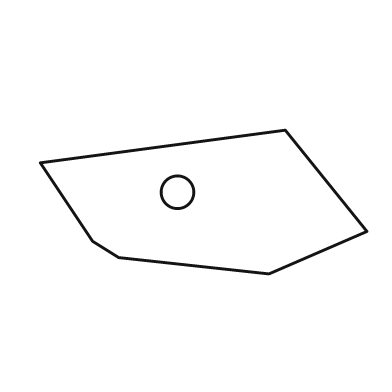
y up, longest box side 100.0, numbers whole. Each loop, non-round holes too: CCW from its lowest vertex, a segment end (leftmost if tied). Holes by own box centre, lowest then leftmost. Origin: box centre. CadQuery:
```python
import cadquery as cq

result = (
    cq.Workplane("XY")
    .moveTo(20.0, -22.0)
    .lineTo(50.0, -9.0)
    .lineTo(25.0, 22.0)
    .lineTo(-50.0, 12.0)
    .lineTo(-34.0, -12.0)
    .lineTo(-26.0, -17.0)
    .close()
    .moveTo(-8.0, 3.0)
    .circle(5.0)
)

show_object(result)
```